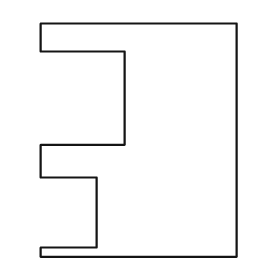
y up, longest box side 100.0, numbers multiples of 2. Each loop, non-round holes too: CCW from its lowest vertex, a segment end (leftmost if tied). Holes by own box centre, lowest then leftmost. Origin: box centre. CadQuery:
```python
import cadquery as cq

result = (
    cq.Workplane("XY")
    .moveTo(-42.0, -50.0)
    .lineTo(42.0, -50.0)
    .lineTo(42.0, 50.0)
    .lineTo(-42.0, 50.0)
    .lineTo(-42.0, 38.0)
    .lineTo(-6.0, 38.0)
    .lineTo(-6.0, -2.0)
    .lineTo(-42.0, -2.0)
    .lineTo(-42.0, -16.0)
    .lineTo(-18.0, -16.0)
    .lineTo(-18.0, -46.0)
    .lineTo(-42.0, -46.0)
    .close()
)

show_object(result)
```